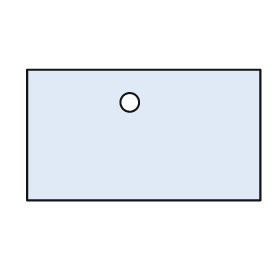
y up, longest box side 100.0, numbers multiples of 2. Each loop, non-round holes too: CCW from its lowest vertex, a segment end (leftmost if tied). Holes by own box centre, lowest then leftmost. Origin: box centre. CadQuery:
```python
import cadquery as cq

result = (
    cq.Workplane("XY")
    .moveTo(-50.0, -28.0)
    .lineTo(50.0, -28.0)
    .lineTo(50.0, 28.0)
    .lineTo(-50.0, 28.0)
    .close()
    .moveTo(-6.0, 14.0)
    .circle(4.0)
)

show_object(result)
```